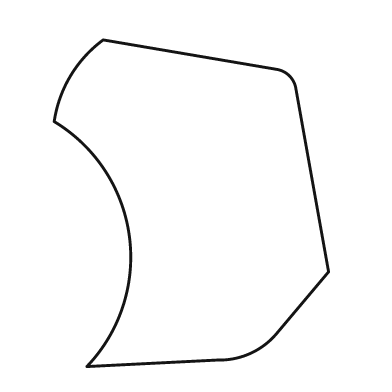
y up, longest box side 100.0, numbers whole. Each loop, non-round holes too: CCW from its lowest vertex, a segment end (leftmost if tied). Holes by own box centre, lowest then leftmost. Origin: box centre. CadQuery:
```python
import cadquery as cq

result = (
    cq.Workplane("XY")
    .moveTo(-32.0, -50.0)
    .lineTo(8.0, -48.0)
    .threePointArc((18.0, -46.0), (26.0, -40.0))
    .lineTo(42.0, -21.0)
    .lineTo(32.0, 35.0)
    .threePointArc((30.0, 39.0), (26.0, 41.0))
    .lineTo(-27.0, 50.0)
    .threePointArc((-37.0, 39.0), (-42.0, 25.0))
    .threePointArc((-19.0, -10.0), (-32.0, -50.0))
    .close()
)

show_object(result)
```